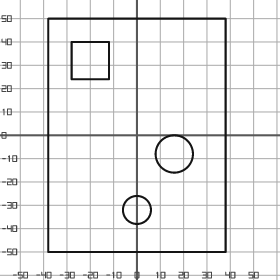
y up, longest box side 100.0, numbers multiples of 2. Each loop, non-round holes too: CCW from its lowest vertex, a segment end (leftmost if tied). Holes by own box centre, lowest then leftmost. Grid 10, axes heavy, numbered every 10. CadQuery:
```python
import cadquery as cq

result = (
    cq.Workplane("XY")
    .moveTo(-38.0, -50.0)
    .lineTo(38.0, -50.0)
    .lineTo(38.0, 50.0)
    .lineTo(-38.0, 50.0)
    .close()
    .moveTo(0.0, -32.0)
    .circle(6.0)
    .moveTo(16.0, -8.0)
    .circle(8.0)
    .moveTo(-28.0, 24.0)
    .lineTo(-12.0, 24.0)
    .lineTo(-12.0, 40.0)
    .lineTo(-28.0, 40.0)
    .close()
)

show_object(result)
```